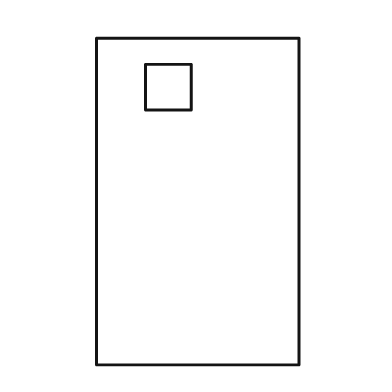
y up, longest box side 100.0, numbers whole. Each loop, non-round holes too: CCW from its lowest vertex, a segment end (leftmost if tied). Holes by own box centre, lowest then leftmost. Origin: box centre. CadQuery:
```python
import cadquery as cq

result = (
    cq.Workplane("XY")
    .moveTo(-31.0, -50.0)
    .lineTo(31.0, -50.0)
    .lineTo(31.0, 50.0)
    .lineTo(-31.0, 50.0)
    .close()
    .moveTo(-16.0, 28.0)
    .lineTo(-2.0, 28.0)
    .lineTo(-2.0, 42.0)
    .lineTo(-16.0, 42.0)
    .close()
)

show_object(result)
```